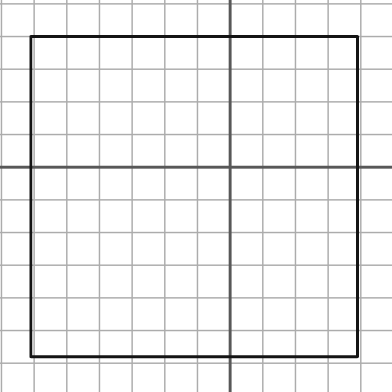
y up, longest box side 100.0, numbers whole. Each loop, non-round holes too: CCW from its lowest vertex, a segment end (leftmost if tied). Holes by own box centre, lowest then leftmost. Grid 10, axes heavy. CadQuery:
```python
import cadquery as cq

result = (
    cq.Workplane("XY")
    .moveTo(-61.0, -58.0)
    .lineTo(39.0, -58.0)
    .lineTo(39.0, 40.0)
    .lineTo(-61.0, 40.0)
    .close()
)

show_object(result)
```